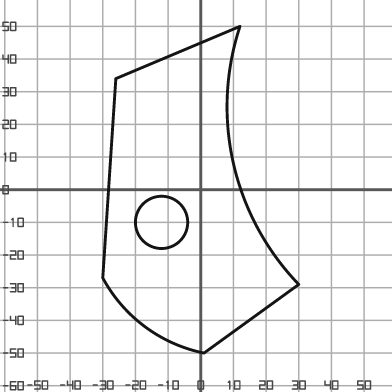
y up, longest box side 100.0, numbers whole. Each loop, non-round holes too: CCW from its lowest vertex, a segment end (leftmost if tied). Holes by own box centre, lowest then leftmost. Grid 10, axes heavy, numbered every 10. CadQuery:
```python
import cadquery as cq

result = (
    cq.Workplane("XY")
    .moveTo(1.0, -50.0)
    .lineTo(30.0, -29.0)
    .threePointArc((10.0, 8.0), (12.0, 50.0))
    .lineTo(-26.0, 34.0)
    .lineTo(-30.0, -27.0)
    .threePointArc((-17.0, -42.0), (1.0, -50.0))
    .close()
    .moveTo(-12.0, -10.0)
    .circle(8.0)
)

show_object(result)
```